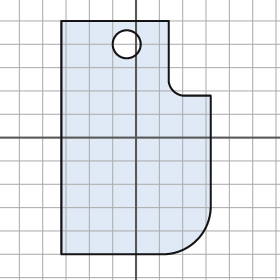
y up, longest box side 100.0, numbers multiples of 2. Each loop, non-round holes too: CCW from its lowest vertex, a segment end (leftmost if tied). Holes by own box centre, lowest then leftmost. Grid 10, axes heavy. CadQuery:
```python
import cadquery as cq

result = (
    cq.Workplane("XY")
    .moveTo(-32.0, -50.0)
    .lineTo(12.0, -50.0)
    .threePointArc((26.0, -44.0), (32.0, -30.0))
    .lineTo(32.0, 18.0)
    .lineTo(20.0, 18.0)
    .threePointArc((16.0, 20.0), (14.0, 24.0))
    .lineTo(14.0, 50.0)
    .lineTo(-32.0, 50.0)
    .close()
    .moveTo(-4.0, 40.0)
    .circle(6.0)
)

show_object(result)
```